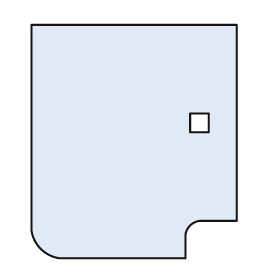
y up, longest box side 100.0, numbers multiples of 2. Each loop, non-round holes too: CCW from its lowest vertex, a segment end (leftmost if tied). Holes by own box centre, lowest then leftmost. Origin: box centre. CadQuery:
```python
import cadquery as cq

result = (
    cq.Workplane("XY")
    .moveTo(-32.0, -50.0)
    .lineTo(22.0, -50.0)
    .lineTo(22.0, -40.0)
    .threePointArc((24.0, -36.0), (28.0, -34.0))
    .lineTo(44.0, -34.0)
    .lineTo(44.0, 50.0)
    .lineTo(-44.0, 50.0)
    .lineTo(-44.0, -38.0)
    .threePointArc((-40.0, -46.0), (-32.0, -50.0))
    .close()
    .moveTo(24.0, 4.0)
    .lineTo(32.0, 4.0)
    .lineTo(32.0, 12.0)
    .lineTo(24.0, 12.0)
    .close()
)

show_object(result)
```